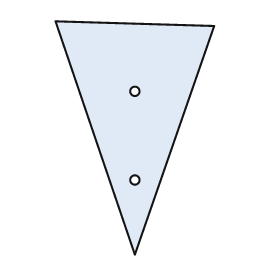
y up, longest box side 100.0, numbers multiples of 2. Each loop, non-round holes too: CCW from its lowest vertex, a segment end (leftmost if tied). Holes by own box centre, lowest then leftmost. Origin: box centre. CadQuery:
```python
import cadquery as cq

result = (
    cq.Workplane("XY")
    .moveTo(0.0, -50.0)
    .lineTo(34.0, 48.0)
    .lineTo(-34.0, 50.0)
    .close()
    .moveTo(0.0, -18.0)
    .circle(2.0)
    .moveTo(0.0, 20.0)
    .circle(2.0)
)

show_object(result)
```